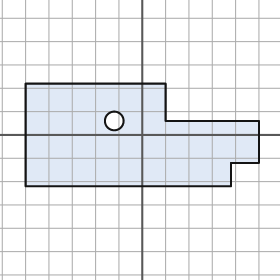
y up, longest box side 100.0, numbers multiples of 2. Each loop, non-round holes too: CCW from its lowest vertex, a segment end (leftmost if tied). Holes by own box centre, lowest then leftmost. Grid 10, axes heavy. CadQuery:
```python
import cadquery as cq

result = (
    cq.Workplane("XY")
    .moveTo(-50.0, -22.0)
    .lineTo(38.0, -22.0)
    .lineTo(38.0, -12.0)
    .lineTo(50.0, -12.0)
    .lineTo(50.0, 6.0)
    .lineTo(10.0, 6.0)
    .lineTo(10.0, 22.0)
    .lineTo(-50.0, 22.0)
    .close()
    .moveTo(-12.0, 6.0)
    .circle(4.0)
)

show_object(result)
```